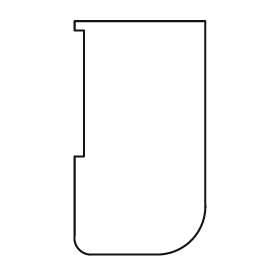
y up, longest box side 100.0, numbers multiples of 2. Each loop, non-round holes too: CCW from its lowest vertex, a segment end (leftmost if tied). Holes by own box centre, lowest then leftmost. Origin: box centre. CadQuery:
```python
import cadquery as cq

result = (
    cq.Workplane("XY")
    .moveTo(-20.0, -50.0)
    .lineTo(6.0, -50.0)
    .threePointArc((22.0, -44.0), (28.0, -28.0))
    .lineTo(28.0, 50.0)
    .lineTo(-28.0, 50.0)
    .lineTo(-28.0, 46.0)
    .lineTo(-24.0, 46.0)
    .lineTo(-24.0, -8.0)
    .lineTo(-28.0, -8.0)
    .lineTo(-28.0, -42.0)
    .threePointArc((-26.0, -48.0), (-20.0, -50.0))
    .close()
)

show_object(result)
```